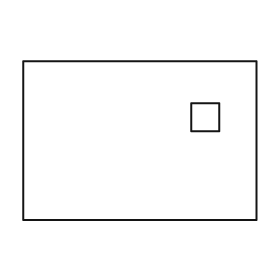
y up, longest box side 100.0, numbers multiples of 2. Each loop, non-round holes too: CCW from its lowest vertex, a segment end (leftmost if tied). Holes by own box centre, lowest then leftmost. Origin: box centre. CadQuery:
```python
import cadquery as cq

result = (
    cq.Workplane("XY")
    .moveTo(-50.0, -34.0)
    .lineTo(50.0, -34.0)
    .lineTo(50.0, 34.0)
    .lineTo(-50.0, 34.0)
    .close()
    .moveTo(22.0, 4.0)
    .lineTo(34.0, 4.0)
    .lineTo(34.0, 16.0)
    .lineTo(22.0, 16.0)
    .close()
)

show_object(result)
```